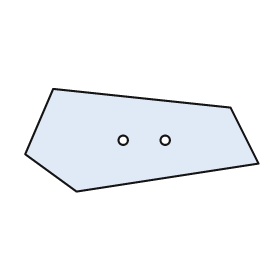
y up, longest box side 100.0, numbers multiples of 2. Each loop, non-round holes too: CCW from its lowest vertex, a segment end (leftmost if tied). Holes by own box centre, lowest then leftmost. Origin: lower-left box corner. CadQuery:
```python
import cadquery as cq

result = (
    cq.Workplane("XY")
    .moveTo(22.0, 0.0)
    .lineTo(100.0, 12.0)
    .lineTo(88.0, 36.0)
    .lineTo(12.0, 44.0)
    .lineTo(0.0, 16.0)
    .close()
    .moveTo(42.0, 22.0)
    .circle(2.0)
    .moveTo(60.0, 22.0)
    .circle(2.0)
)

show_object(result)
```